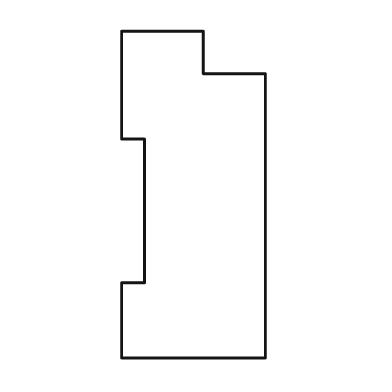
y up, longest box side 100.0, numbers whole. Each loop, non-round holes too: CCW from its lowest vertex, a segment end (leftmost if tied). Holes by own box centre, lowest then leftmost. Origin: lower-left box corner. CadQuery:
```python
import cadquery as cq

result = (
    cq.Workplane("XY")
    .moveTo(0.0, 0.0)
    .lineTo(44.0, 0.0)
    .lineTo(44.0, 87.0)
    .lineTo(25.0, 87.0)
    .lineTo(25.0, 100.0)
    .lineTo(0.0, 100.0)
    .lineTo(0.0, 67.0)
    .lineTo(7.0, 67.0)
    .lineTo(7.0, 23.0)
    .lineTo(0.0, 23.0)
    .close()
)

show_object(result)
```